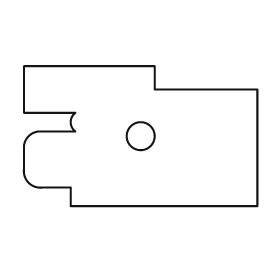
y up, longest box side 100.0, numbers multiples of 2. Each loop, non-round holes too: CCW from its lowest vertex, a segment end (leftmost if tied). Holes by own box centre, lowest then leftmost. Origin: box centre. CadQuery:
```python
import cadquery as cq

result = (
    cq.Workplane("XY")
    .moveTo(-30.0, -30.0)
    .lineTo(50.0, -30.0)
    .lineTo(50.0, 20.0)
    .lineTo(6.0, 20.0)
    .lineTo(6.0, 30.0)
    .lineTo(-50.0, 30.0)
    .lineTo(-50.0, 10.0)
    .lineTo(-28.0, 10.0)
    .threePointArc((-30.0, 6.0), (-28.0, 2.0))
    .lineTo(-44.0, 2.0)
    .threePointArc((-48.0, 0.0), (-50.0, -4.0))
    .lineTo(-50.0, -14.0)
    .threePointArc((-48.0, -20.0), (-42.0, -22.0))
    .lineTo(-30.0, -22.0)
    .close()
    .moveTo(0.0, 0.0)
    .circle(6.0)
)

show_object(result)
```